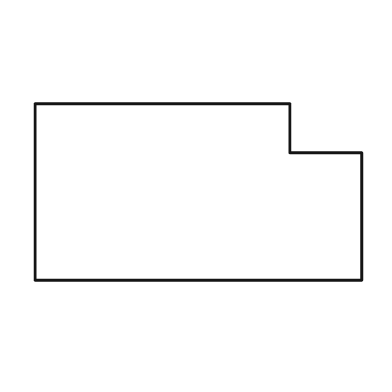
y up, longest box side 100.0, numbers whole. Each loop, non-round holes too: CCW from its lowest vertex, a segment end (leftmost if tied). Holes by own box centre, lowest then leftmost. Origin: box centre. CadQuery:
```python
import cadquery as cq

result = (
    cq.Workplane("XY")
    .moveTo(-50.0, -27.0)
    .lineTo(50.0, -27.0)
    .lineTo(50.0, 12.0)
    .lineTo(28.0, 12.0)
    .lineTo(28.0, 27.0)
    .lineTo(-50.0, 27.0)
    .close()
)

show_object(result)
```